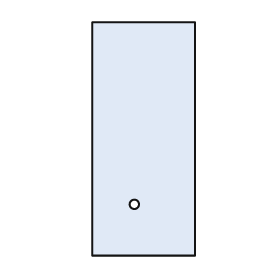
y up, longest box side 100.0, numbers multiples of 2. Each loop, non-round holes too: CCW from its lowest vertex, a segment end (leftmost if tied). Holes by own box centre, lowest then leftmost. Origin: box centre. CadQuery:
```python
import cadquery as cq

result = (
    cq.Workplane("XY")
    .moveTo(-22.0, -50.0)
    .lineTo(22.0, -50.0)
    .lineTo(22.0, 50.0)
    .lineTo(-22.0, 50.0)
    .close()
    .moveTo(-4.0, -28.0)
    .circle(2.0)
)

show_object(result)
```